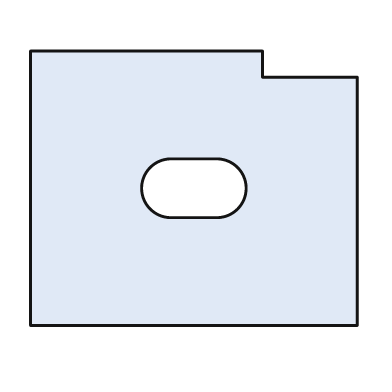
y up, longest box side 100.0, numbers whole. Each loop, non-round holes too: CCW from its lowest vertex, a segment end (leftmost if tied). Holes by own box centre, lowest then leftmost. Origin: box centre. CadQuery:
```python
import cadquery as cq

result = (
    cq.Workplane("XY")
    .moveTo(-50.0, -42.0)
    .lineTo(50.0, -42.0)
    .lineTo(50.0, 34.0)
    .lineTo(21.0, 34.0)
    .lineTo(21.0, 42.0)
    .lineTo(-50.0, 42.0)
    .close()
    .moveTo(-7.0, -9.0)
    .lineTo(7.0, -9.0)
    .threePointArc((16.0, 0.0), (7.0, 9.0))
    .lineTo(-7.0, 9.0)
    .threePointArc((-16.0, 0.0), (-7.0, -9.0))
    .close()
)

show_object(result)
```